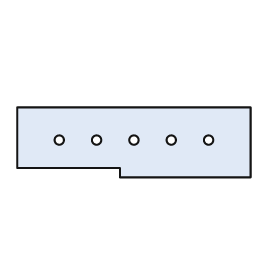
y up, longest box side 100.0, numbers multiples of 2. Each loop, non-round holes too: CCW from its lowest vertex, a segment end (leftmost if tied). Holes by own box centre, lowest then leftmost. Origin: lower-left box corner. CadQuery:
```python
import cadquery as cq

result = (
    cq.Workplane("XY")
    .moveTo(44.0, 0.0)
    .lineTo(100.0, 0.0)
    .lineTo(100.0, 30.0)
    .lineTo(0.0, 30.0)
    .lineTo(0.0, 4.0)
    .lineTo(44.0, 4.0)
    .close()
    .moveTo(18.0, 16.0)
    .circle(2.0)
    .moveTo(34.0, 16.0)
    .circle(2.0)
    .moveTo(50.0, 16.0)
    .circle(2.0)
    .moveTo(66.0, 16.0)
    .circle(2.0)
    .moveTo(82.0, 16.0)
    .circle(2.0)
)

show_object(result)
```